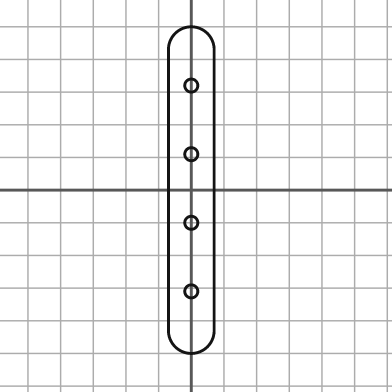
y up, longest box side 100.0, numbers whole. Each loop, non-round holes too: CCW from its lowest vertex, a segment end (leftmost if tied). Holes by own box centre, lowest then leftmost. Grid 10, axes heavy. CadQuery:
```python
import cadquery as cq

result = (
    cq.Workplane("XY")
    .moveTo(-7.0, -43.0)
    .threePointArc((0.0, -50.0), (7.0, -43.0))
    .lineTo(7.0, 43.0)
    .threePointArc((0.0, 50.0), (-7.0, 43.0))
    .close()
    .moveTo(0.0, -31.0)
    .circle(2.0)
    .moveTo(0.0, -10.0)
    .circle(2.0)
    .moveTo(0.0, 11.0)
    .circle(2.0)
    .moveTo(0.0, 32.0)
    .circle(2.0)
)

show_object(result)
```